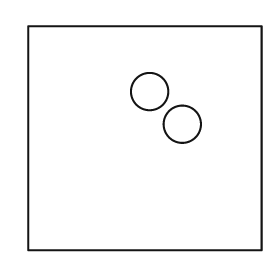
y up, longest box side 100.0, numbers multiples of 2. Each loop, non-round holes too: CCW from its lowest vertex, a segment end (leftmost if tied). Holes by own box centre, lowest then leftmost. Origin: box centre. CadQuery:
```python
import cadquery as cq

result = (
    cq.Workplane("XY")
    .moveTo(-50.0, -48.0)
    .lineTo(50.0, -48.0)
    .lineTo(50.0, 48.0)
    .lineTo(-50.0, 48.0)
    .close()
    .moveTo(16.0, 6.0)
    .circle(8.0)
    .moveTo(2.0, 20.0)
    .circle(8.0)
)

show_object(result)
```